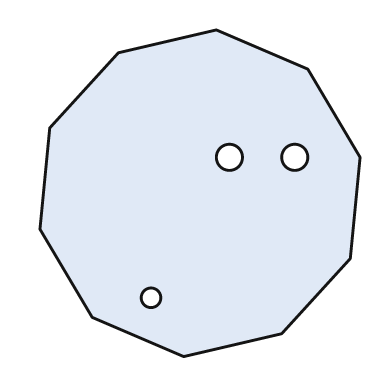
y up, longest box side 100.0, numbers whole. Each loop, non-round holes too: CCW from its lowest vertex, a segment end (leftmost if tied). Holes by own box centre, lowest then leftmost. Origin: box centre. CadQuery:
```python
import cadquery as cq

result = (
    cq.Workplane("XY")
    .moveTo(-5.0, -50.0)
    .lineTo(25.0, -43.0)
    .lineTo(46.0, -20.0)
    .lineTo(49.0, 11.0)
    .lineTo(33.0, 38.0)
    .lineTo(5.0, 50.0)
    .lineTo(-25.0, 43.0)
    .lineTo(-46.0, 20.0)
    .lineTo(-49.0, -11.0)
    .lineTo(-33.0, -38.0)
    .close()
    .moveTo(-15.0, -32.0)
    .circle(3.0)
    .moveTo(9.0, 11.0)
    .circle(4.0)
    .moveTo(29.0, 11.0)
    .circle(4.0)
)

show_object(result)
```